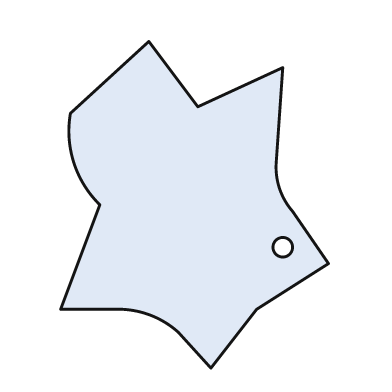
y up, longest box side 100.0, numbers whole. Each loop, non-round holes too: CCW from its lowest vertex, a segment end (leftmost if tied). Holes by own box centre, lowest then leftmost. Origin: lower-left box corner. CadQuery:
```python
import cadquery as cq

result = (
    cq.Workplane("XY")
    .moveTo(46.0, 0.0)
    .lineTo(60.0, 18.0)
    .lineTo(82.0, 32.0)
    .lineTo(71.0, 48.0)
    .threePointArc((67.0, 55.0), (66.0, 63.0))
    .lineTo(68.0, 92.0)
    .lineTo(42.0, 80.0)
    .lineTo(27.0, 100.0)
    .lineTo(3.0, 78.0)
    .threePointArc((4.0, 63.0), (12.0, 50.0))
    .lineTo(0.0, 18.0)
    .lineTo(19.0, 18.0)
    .threePointArc((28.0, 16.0), (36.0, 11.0))
    .close()
    .moveTo(68.0, 37.0)
    .circle(3.0)
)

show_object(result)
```